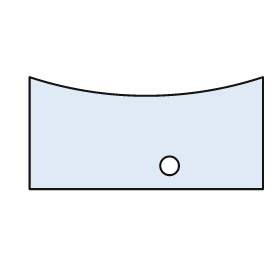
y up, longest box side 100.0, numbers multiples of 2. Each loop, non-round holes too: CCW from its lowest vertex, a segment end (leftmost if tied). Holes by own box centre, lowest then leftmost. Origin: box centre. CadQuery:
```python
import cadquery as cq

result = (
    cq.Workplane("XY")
    .moveTo(-50.0, -24.0)
    .lineTo(50.0, -24.0)
    .lineTo(50.0, 24.0)
    .threePointArc((0.0, 16.0), (-50.0, 24.0))
    .close()
    .moveTo(10.0, -14.0)
    .circle(4.0)
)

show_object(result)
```